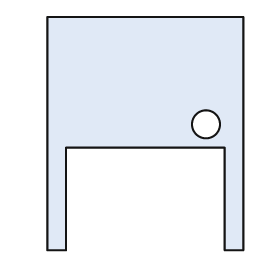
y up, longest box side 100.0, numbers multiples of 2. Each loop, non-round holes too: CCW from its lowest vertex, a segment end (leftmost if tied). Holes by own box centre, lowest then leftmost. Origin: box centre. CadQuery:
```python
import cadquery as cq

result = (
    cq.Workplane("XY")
    .moveTo(-42.0, -50.0)
    .lineTo(-34.0, -50.0)
    .lineTo(-34.0, -6.0)
    .lineTo(34.0, -6.0)
    .lineTo(34.0, -50.0)
    .lineTo(42.0, -50.0)
    .lineTo(42.0, 50.0)
    .lineTo(-42.0, 50.0)
    .close()
    .moveTo(26.0, 4.0)
    .circle(6.0)
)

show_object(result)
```